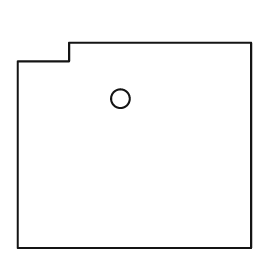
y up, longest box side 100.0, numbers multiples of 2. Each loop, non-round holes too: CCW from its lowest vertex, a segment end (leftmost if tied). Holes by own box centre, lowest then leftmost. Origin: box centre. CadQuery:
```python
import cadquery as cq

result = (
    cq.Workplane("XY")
    .moveTo(-50.0, -44.0)
    .lineTo(50.0, -44.0)
    .lineTo(50.0, 44.0)
    .lineTo(-28.0, 44.0)
    .lineTo(-28.0, 36.0)
    .lineTo(-50.0, 36.0)
    .close()
    .moveTo(-6.0, 20.0)
    .circle(4.0)
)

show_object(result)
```